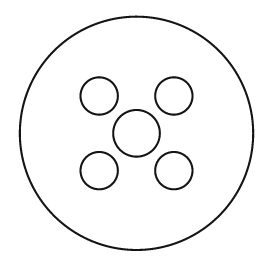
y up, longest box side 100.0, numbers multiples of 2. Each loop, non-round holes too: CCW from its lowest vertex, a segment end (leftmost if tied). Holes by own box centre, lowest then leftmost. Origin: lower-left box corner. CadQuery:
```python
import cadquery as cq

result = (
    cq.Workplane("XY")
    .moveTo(50.0, 50.0)
    .circle(50.0)
    .moveTo(34.0, 34.0)
    .circle(8.0)
    .moveTo(66.0, 34.0)
    .circle(8.0)
    .moveTo(50.0, 50.0)
    .circle(10.0)
    .moveTo(34.0, 66.0)
    .circle(8.0)
    .moveTo(66.0, 66.0)
    .circle(8.0)
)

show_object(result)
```